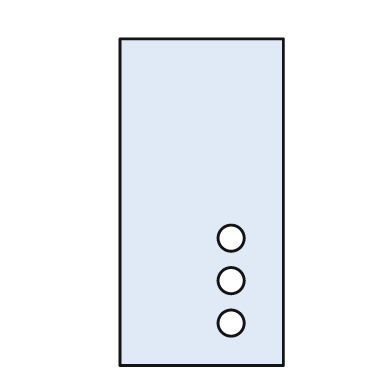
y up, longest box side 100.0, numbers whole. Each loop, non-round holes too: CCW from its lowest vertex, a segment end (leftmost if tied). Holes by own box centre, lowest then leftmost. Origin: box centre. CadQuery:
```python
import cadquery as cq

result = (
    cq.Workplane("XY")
    .moveTo(-25.0, -50.0)
    .lineTo(25.0, -50.0)
    .lineTo(25.0, 50.0)
    .lineTo(-25.0, 50.0)
    .close()
    .moveTo(9.0, -37.0)
    .circle(4.0)
    .moveTo(9.0, -24.0)
    .circle(4.0)
    .moveTo(9.0, -11.0)
    .circle(4.0)
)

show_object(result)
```